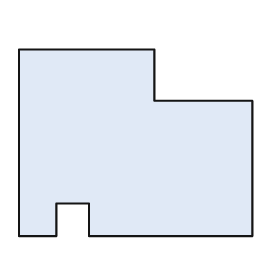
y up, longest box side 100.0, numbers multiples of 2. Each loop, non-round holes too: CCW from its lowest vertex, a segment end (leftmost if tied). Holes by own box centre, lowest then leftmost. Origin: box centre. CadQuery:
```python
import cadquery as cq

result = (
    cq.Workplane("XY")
    .moveTo(-50.0, -40.0)
    .lineTo(-34.0, -40.0)
    .lineTo(-34.0, -26.0)
    .lineTo(-20.0, -26.0)
    .lineTo(-20.0, -40.0)
    .lineTo(50.0, -40.0)
    .lineTo(50.0, 18.0)
    .lineTo(8.0, 18.0)
    .lineTo(8.0, 40.0)
    .lineTo(-50.0, 40.0)
    .close()
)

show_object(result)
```